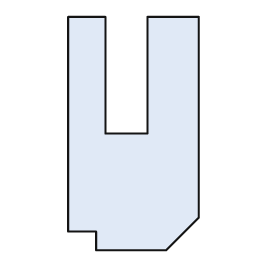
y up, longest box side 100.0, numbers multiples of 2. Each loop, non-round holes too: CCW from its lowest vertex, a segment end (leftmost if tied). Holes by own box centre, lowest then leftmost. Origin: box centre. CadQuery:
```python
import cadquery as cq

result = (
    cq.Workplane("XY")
    .moveTo(-16.0, -50.0)
    .lineTo(14.0, -50.0)
    .lineTo(28.0, -36.0)
    .lineTo(28.0, 50.0)
    .lineTo(6.0, 50.0)
    .lineTo(6.0, 0.0)
    .lineTo(-12.0, 0.0)
    .lineTo(-12.0, 50.0)
    .lineTo(-28.0, 50.0)
    .lineTo(-28.0, -42.0)
    .lineTo(-16.0, -42.0)
    .close()
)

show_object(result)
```